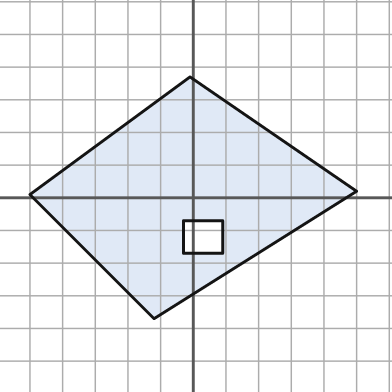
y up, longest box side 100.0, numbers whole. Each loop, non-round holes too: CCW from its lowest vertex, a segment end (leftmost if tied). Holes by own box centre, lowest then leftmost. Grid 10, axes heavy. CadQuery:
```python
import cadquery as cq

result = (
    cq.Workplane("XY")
    .moveTo(-12.0, -37.0)
    .lineTo(50.0, 2.0)
    .lineTo(-1.0, 37.0)
    .lineTo(-50.0, 1.0)
    .close()
    .moveTo(-3.0, -17.0)
    .lineTo(9.0, -17.0)
    .lineTo(9.0, -7.0)
    .lineTo(-3.0, -7.0)
    .close()
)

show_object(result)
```